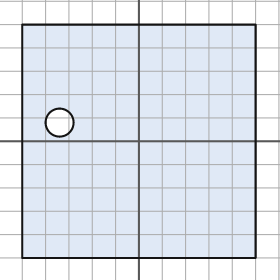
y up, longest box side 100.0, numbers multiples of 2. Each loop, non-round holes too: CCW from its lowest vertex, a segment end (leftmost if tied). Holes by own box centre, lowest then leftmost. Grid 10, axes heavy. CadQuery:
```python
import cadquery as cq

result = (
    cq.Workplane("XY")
    .moveTo(-50.0, -50.0)
    .lineTo(50.0, -50.0)
    .lineTo(50.0, 50.0)
    .lineTo(-50.0, 50.0)
    .close()
    .moveTo(-34.0, 8.0)
    .circle(6.0)
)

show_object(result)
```